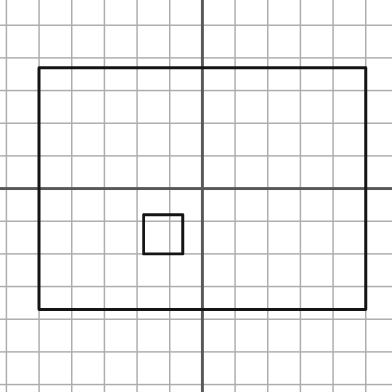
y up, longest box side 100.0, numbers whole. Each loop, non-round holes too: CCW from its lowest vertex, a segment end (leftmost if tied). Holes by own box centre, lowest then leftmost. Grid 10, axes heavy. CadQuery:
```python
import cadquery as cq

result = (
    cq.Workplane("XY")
    .moveTo(-50.0, -37.0)
    .lineTo(50.0, -37.0)
    .lineTo(50.0, 37.0)
    .lineTo(-50.0, 37.0)
    .close()
    .moveTo(-18.0, -20.0)
    .lineTo(-6.0, -20.0)
    .lineTo(-6.0, -8.0)
    .lineTo(-18.0, -8.0)
    .close()
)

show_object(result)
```